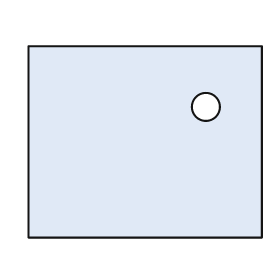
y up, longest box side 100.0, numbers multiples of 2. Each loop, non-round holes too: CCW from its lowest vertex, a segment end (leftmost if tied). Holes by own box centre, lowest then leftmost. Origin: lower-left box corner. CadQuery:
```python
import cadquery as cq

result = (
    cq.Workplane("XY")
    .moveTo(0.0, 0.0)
    .lineTo(100.0, 0.0)
    .lineTo(100.0, 82.0)
    .lineTo(0.0, 82.0)
    .close()
    .moveTo(76.0, 56.0)
    .circle(6.0)
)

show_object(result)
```